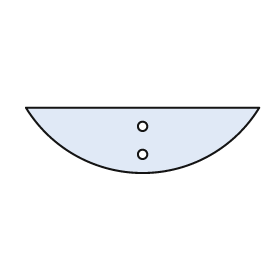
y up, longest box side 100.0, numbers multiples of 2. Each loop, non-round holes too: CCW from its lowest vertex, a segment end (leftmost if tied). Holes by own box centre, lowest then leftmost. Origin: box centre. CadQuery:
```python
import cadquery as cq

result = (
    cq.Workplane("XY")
    .moveTo(-50.0, 14.0)
    .threePointArc((0.0, -14.0), (50.0, 14.0))
    .close()
    .moveTo(0.0, -6.0)
    .circle(2.0)
    .moveTo(0.0, 6.0)
    .circle(2.0)
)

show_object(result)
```